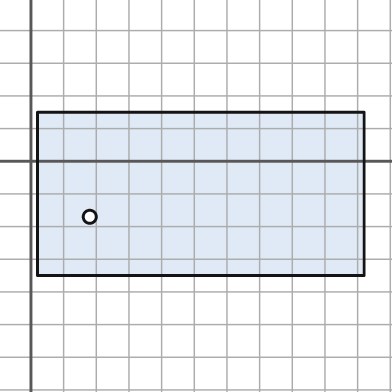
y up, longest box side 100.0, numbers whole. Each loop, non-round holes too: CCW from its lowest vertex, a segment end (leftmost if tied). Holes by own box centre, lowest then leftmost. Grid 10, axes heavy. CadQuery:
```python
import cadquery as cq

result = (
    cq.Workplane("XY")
    .moveTo(2.0, -35.0)
    .lineTo(102.0, -35.0)
    .lineTo(102.0, 15.0)
    .lineTo(2.0, 15.0)
    .close()
    .moveTo(18.0, -17.0)
    .circle(2.0)
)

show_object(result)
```